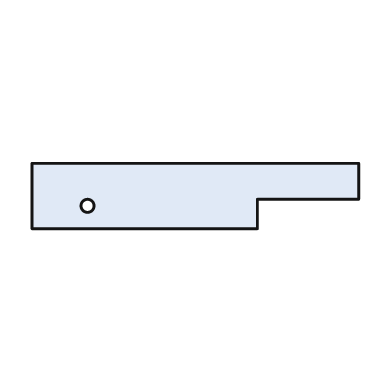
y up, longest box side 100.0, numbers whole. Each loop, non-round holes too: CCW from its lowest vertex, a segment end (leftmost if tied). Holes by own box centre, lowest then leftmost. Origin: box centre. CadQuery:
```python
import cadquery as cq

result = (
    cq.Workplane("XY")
    .moveTo(-50.0, -10.0)
    .lineTo(19.0, -10.0)
    .lineTo(19.0, -1.0)
    .lineTo(50.0, -1.0)
    .lineTo(50.0, 10.0)
    .lineTo(-50.0, 10.0)
    .close()
    .moveTo(-33.0, -3.0)
    .circle(2.0)
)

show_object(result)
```